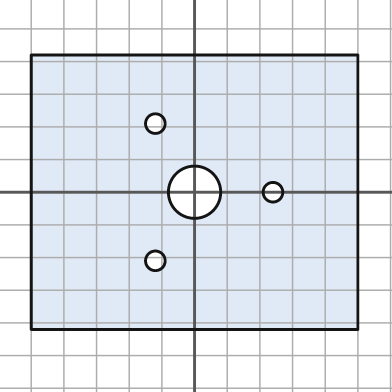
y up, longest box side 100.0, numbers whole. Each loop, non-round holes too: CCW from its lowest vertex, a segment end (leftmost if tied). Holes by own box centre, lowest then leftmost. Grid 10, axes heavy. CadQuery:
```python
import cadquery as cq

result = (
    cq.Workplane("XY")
    .moveTo(-50.0, -42.0)
    .lineTo(50.0, -42.0)
    .lineTo(50.0, 42.0)
    .lineTo(-50.0, 42.0)
    .close()
    .moveTo(-12.0, -21.0)
    .circle(3.0)
    .moveTo(0.0, 0.0)
    .circle(8.0)
    .moveTo(24.0, 0.0)
    .circle(3.0)
    .moveTo(-12.0, 21.0)
    .circle(3.0)
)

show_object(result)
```